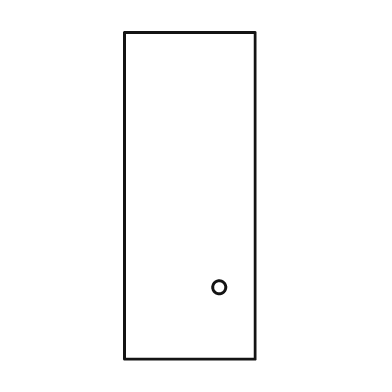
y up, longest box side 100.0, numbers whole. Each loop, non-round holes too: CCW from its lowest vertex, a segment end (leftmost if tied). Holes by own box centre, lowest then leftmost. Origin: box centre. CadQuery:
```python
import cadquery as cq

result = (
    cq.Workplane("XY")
    .moveTo(-20.0, -50.0)
    .lineTo(20.0, -50.0)
    .lineTo(20.0, 50.0)
    .lineTo(-20.0, 50.0)
    .close()
    .moveTo(9.0, -28.0)
    .circle(2.0)
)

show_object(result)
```